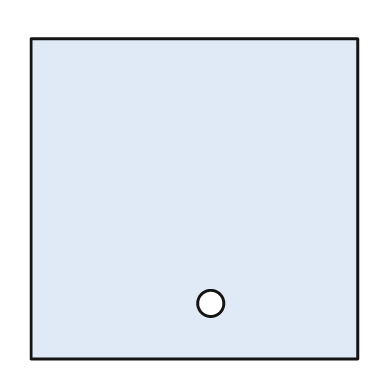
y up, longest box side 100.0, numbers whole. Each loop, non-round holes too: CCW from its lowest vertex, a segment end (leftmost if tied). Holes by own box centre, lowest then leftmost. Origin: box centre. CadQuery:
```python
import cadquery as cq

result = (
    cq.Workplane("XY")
    .moveTo(-50.0, -49.0)
    .lineTo(50.0, -49.0)
    .lineTo(50.0, 49.0)
    .lineTo(-50.0, 49.0)
    .close()
    .moveTo(5.0, -32.0)
    .circle(4.0)
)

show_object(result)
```